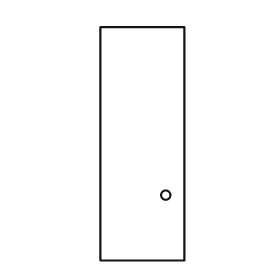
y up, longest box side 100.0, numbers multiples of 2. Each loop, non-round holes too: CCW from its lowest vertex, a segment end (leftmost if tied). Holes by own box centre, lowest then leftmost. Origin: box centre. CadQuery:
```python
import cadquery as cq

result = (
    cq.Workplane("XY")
    .moveTo(-18.0, -50.0)
    .lineTo(18.0, -50.0)
    .lineTo(18.0, 50.0)
    .lineTo(-18.0, 50.0)
    .close()
    .moveTo(10.0, -22.0)
    .circle(2.0)
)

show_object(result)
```